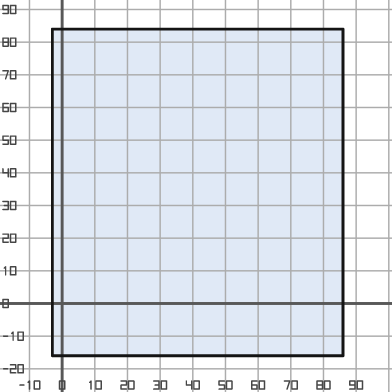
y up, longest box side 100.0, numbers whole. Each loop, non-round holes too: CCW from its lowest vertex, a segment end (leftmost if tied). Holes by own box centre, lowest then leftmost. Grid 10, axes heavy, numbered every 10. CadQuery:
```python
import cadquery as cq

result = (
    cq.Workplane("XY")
    .moveTo(-3.0, -16.0)
    .lineTo(86.0, -16.0)
    .lineTo(86.0, 84.0)
    .lineTo(-3.0, 84.0)
    .close()
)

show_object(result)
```